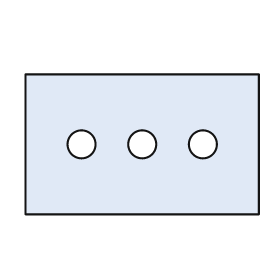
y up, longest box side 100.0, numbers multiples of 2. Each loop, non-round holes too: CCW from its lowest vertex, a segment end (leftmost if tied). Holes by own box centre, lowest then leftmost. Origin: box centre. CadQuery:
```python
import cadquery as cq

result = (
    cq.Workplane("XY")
    .moveTo(-50.0, -30.0)
    .lineTo(50.0, -30.0)
    .lineTo(50.0, 30.0)
    .lineTo(-50.0, 30.0)
    .close()
    .moveTo(-26.0, 0.0)
    .circle(6.0)
    .moveTo(0.0, 0.0)
    .circle(6.0)
    .moveTo(26.0, 0.0)
    .circle(6.0)
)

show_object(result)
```